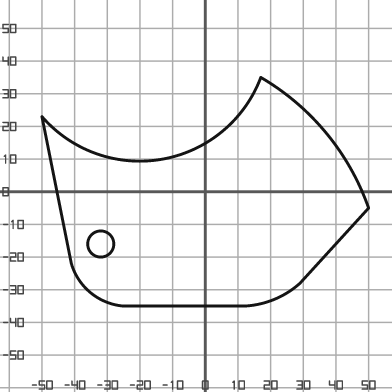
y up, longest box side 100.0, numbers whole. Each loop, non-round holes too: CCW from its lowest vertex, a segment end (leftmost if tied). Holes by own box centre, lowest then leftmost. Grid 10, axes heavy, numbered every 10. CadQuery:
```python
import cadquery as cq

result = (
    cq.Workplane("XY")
    .moveTo(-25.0, -35.0)
    .lineTo(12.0, -35.0)
    .threePointArc((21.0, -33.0), (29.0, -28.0))
    .lineTo(50.0, -5.0)
    .threePointArc((37.0, 18.0), (17.0, 35.0))
    .threePointArc((-13.0, 10.0), (-50.0, 23.0))
    .lineTo(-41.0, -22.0)
    .threePointArc((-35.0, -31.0), (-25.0, -35.0))
    .close()
    .moveTo(-32.0, -16.0)
    .circle(4.0)
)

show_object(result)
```